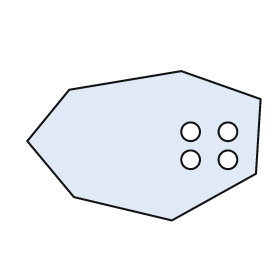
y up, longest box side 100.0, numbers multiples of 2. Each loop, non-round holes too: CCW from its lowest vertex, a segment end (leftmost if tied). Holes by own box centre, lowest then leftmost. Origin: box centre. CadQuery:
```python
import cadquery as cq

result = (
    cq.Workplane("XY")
    .moveTo(12.0, -32.0)
    .lineTo(48.0, -12.0)
    .lineTo(50.0, 20.0)
    .lineTo(16.0, 32.0)
    .lineTo(-32.0, 24.0)
    .lineTo(-50.0, 2.0)
    .lineTo(-30.0, -22.0)
    .close()
    .moveTo(20.0, -6.0)
    .circle(4.0)
    .moveTo(36.0, -6.0)
    .circle(4.0)
    .moveTo(20.0, 6.0)
    .circle(4.0)
    .moveTo(36.0, 6.0)
    .circle(4.0)
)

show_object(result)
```